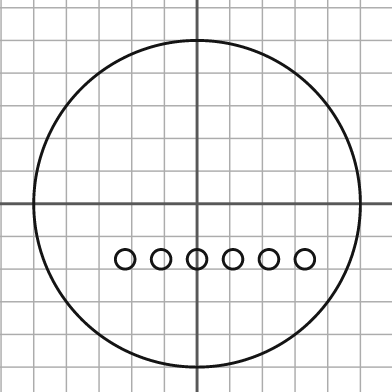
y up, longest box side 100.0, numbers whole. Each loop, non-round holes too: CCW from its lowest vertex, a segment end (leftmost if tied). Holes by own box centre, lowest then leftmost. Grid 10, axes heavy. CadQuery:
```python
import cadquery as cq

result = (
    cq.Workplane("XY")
    .moveTo(0.0, 0.0)
    .circle(50.0)
    .moveTo(-22.0, -17.0)
    .circle(3.0)
    .moveTo(-11.0, -17.0)
    .circle(3.0)
    .moveTo(0.0, -17.0)
    .circle(3.0)
    .moveTo(11.0, -17.0)
    .circle(3.0)
    .moveTo(22.0, -17.0)
    .circle(3.0)
    .moveTo(33.0, -17.0)
    .circle(3.0)
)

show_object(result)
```